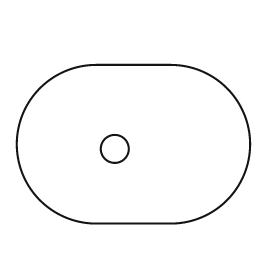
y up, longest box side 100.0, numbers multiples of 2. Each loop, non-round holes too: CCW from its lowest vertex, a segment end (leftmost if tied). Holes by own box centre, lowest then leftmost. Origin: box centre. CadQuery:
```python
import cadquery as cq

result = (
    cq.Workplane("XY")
    .moveTo(-16.0, -34.0)
    .lineTo(16.0, -34.0)
    .threePointArc((50.0, 0.0), (16.0, 34.0))
    .lineTo(-16.0, 34.0)
    .threePointArc((-50.0, 0.0), (-16.0, -34.0))
    .close()
    .moveTo(-8.0, -2.0)
    .circle(6.0)
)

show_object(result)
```